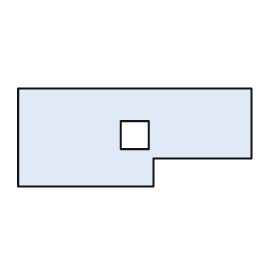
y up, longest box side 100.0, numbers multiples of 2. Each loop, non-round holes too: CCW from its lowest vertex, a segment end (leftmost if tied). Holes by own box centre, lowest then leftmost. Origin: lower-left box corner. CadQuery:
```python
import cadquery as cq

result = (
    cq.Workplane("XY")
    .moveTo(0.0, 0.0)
    .lineTo(58.0, 0.0)
    .lineTo(58.0, 12.0)
    .lineTo(100.0, 12.0)
    .lineTo(100.0, 42.0)
    .lineTo(0.0, 42.0)
    .close()
    .moveTo(44.0, 16.0)
    .lineTo(56.0, 16.0)
    .lineTo(56.0, 28.0)
    .lineTo(44.0, 28.0)
    .close()
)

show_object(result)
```